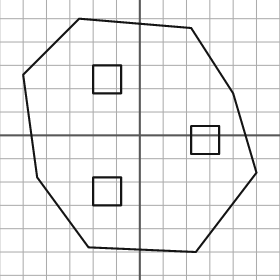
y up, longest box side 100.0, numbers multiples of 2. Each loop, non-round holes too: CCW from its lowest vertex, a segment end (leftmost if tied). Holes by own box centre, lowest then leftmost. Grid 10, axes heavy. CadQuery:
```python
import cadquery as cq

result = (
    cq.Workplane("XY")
    .moveTo(24.0, -50.0)
    .lineTo(50.0, -16.0)
    .lineTo(40.0, 18.0)
    .lineTo(22.0, 46.0)
    .lineTo(-26.0, 50.0)
    .lineTo(-50.0, 26.0)
    .lineTo(-44.0, -18.0)
    .lineTo(-22.0, -48.0)
    .close()
    .moveTo(-20.0, -30.0)
    .lineTo(-8.0, -30.0)
    .lineTo(-8.0, -18.0)
    .lineTo(-20.0, -18.0)
    .close()
    .moveTo(22.0, -8.0)
    .lineTo(34.0, -8.0)
    .lineTo(34.0, 4.0)
    .lineTo(22.0, 4.0)
    .close()
    .moveTo(-20.0, 18.0)
    .lineTo(-8.0, 18.0)
    .lineTo(-8.0, 30.0)
    .lineTo(-20.0, 30.0)
    .close()
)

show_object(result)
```